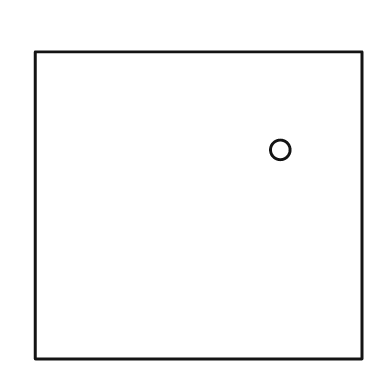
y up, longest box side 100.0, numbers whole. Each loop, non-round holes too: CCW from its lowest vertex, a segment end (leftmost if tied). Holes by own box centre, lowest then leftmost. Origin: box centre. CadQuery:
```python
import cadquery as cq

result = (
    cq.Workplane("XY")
    .moveTo(-50.0, -47.0)
    .lineTo(50.0, -47.0)
    .lineTo(50.0, 47.0)
    .lineTo(-50.0, 47.0)
    .close()
    .moveTo(25.0, 17.0)
    .circle(3.0)
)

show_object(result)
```